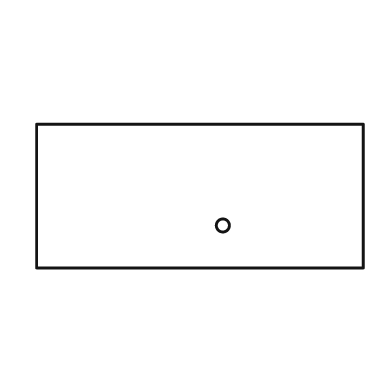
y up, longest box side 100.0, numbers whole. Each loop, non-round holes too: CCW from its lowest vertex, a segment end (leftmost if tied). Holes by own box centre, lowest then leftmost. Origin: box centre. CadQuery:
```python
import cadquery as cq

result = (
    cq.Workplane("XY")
    .moveTo(-50.0, -22.0)
    .lineTo(50.0, -22.0)
    .lineTo(50.0, 22.0)
    .lineTo(-50.0, 22.0)
    .close()
    .moveTo(7.0, -9.0)
    .circle(2.0)
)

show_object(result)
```